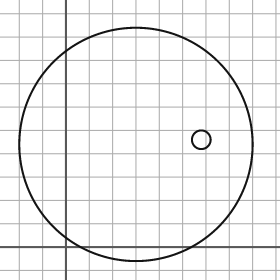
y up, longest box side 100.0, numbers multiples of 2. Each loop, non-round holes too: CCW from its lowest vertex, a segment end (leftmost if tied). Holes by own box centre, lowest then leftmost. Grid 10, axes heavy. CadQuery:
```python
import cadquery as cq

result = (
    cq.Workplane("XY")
    .moveTo(30.0, 44.0)
    .circle(50.0)
    .moveTo(58.0, 46.0)
    .circle(4.0)
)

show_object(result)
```